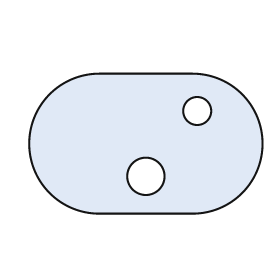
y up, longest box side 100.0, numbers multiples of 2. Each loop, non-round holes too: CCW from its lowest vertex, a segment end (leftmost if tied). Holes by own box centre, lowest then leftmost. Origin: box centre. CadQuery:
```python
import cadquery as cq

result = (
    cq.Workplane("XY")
    .moveTo(-20.0, -30.0)
    .lineTo(20.0, -30.0)
    .threePointArc((50.0, 0.0), (20.0, 30.0))
    .lineTo(-20.0, 30.0)
    .threePointArc((-50.0, 0.0), (-20.0, -30.0))
    .close()
    .moveTo(0.0, -14.0)
    .circle(8.0)
    .moveTo(22.0, 14.0)
    .circle(6.0)
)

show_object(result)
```